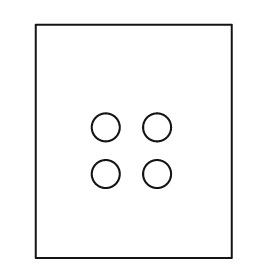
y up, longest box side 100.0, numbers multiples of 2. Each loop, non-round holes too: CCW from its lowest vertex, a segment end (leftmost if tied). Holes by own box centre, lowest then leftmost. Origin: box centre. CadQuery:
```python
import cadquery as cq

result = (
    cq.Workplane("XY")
    .moveTo(-42.0, -50.0)
    .lineTo(42.0, -50.0)
    .lineTo(42.0, 50.0)
    .lineTo(-42.0, 50.0)
    .close()
    .moveTo(-12.0, -14.0)
    .circle(6.0)
    .moveTo(10.0, -14.0)
    .circle(6.0)
    .moveTo(-12.0, 6.0)
    .circle(6.0)
    .moveTo(10.0, 6.0)
    .circle(6.0)
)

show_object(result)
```